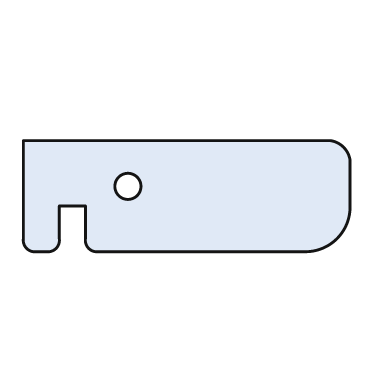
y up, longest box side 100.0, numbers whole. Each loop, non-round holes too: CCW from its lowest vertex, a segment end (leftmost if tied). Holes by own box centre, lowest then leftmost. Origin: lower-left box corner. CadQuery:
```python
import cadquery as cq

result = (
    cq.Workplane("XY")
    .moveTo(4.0, 0.0)
    .lineTo(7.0, 0.0)
    .threePointArc((10.0, 1.0), (11.0, 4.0))
    .lineTo(11.0, 14.0)
    .lineTo(19.0, 14.0)
    .lineTo(19.0, 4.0)
    .threePointArc((20.0, 1.0), (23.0, 0.0))
    .lineTo(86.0, 0.0)
    .threePointArc((96.0, 4.0), (100.0, 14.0))
    .lineTo(100.0, 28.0)
    .threePointArc((98.0, 32.0), (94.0, 34.0))
    .lineTo(0.0, 34.0)
    .lineTo(0.0, 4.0)
    .threePointArc((1.0, 1.0), (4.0, 0.0))
    .close()
    .moveTo(32.0, 20.0)
    .circle(4.0)
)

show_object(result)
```